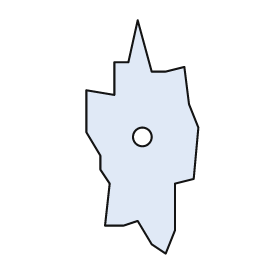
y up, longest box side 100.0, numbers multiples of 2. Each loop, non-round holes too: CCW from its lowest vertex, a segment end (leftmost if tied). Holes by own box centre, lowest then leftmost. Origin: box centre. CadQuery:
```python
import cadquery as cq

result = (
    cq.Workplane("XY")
    .moveTo(10.0, -50.0)
    .lineTo(14.0, -40.0)
    .lineTo(14.0, -20.0)
    .lineTo(22.0, -18.0)
    .lineTo(24.0, 4.0)
    .lineTo(20.0, 14.0)
    .lineTo(18.0, 30.0)
    .lineTo(10.0, 28.0)
    .lineTo(4.0, 28.0)
    .lineTo(-2.0, 50.0)
    .lineTo(-6.0, 32.0)
    .lineTo(-12.0, 32.0)
    .lineTo(-12.0, 18.0)
    .lineTo(-24.0, 20.0)
    .lineTo(-24.0, 2.0)
    .lineTo(-18.0, -8.0)
    .lineTo(-18.0, -14.0)
    .lineTo(-14.0, -20.0)
    .lineTo(-16.0, -38.0)
    .lineTo(-8.0, -38.0)
    .lineTo(-2.0, -36.0)
    .lineTo(4.0, -46.0)
    .close()
    .moveTo(0.0, 0.0)
    .circle(4.0)
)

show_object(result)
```